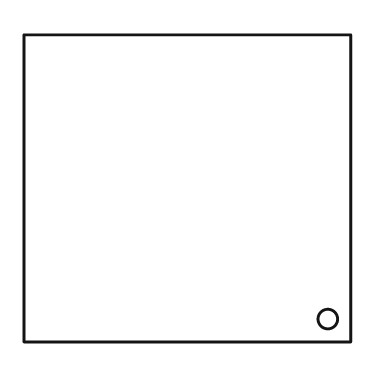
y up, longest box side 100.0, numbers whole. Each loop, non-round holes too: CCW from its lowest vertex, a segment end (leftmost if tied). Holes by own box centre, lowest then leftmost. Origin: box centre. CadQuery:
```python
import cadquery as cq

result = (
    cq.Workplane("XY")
    .moveTo(-50.0, -47.0)
    .lineTo(50.0, -47.0)
    .lineTo(50.0, 47.0)
    .lineTo(-50.0, 47.0)
    .close()
    .moveTo(43.0, -40.0)
    .circle(3.0)
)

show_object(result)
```